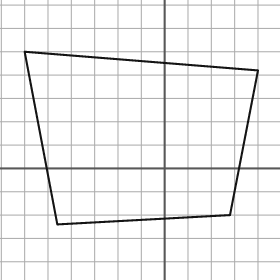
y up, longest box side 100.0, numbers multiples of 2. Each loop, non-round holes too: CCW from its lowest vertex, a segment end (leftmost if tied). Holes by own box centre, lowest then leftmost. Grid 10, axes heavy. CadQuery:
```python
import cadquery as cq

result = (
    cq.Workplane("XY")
    .moveTo(-46.0, -24.0)
    .lineTo(28.0, -20.0)
    .lineTo(40.0, 42.0)
    .lineTo(-60.0, 50.0)
    .close()
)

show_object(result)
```